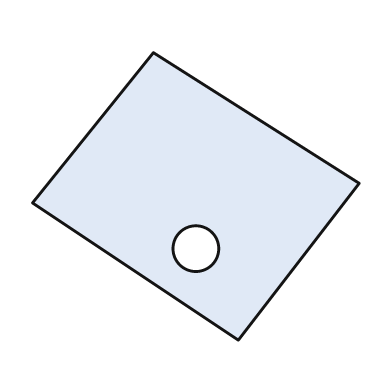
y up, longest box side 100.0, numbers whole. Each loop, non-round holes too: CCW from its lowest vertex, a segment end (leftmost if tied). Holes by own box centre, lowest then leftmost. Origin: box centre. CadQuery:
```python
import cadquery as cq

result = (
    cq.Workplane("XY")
    .moveTo(13.0, -44.0)
    .lineTo(50.0, 4.0)
    .lineTo(-13.0, 44.0)
    .lineTo(-50.0, -2.0)
    .close()
    .moveTo(0.0, -16.0)
    .circle(7.0)
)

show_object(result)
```